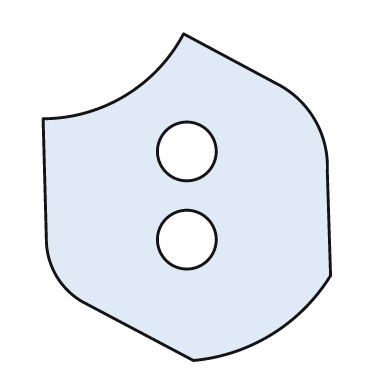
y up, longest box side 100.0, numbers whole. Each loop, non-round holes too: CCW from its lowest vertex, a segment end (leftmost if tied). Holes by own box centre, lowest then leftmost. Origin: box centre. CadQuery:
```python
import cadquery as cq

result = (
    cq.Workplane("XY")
    .moveTo(2.0, -50.0)
    .threePointArc((26.0, -42.0), (44.0, -24.0))
    .lineTo(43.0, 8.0)
    .threePointArc((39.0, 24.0), (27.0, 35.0))
    .lineTo(-1.0, 50.0)
    .threePointArc((-19.0, 31.0), (-44.0, 24.0))
    .lineTo(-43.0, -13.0)
    .threePointArc((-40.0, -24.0), (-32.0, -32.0))
    .close()
    .moveTo(0.0, -13.0)
    .circle(9.0)
    .moveTo(0.0, 14.0)
    .circle(9.0)
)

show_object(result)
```